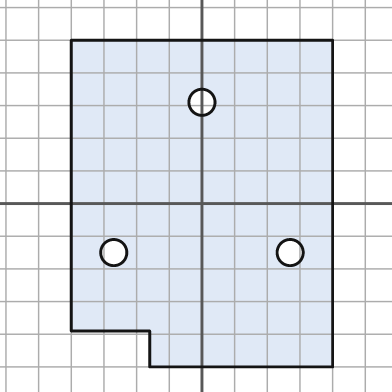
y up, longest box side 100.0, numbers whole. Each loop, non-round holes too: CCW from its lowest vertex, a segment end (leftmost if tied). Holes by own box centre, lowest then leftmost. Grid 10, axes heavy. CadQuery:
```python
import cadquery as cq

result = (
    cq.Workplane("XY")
    .moveTo(-16.0, -50.0)
    .lineTo(40.0, -50.0)
    .lineTo(40.0, 50.0)
    .lineTo(-40.0, 50.0)
    .lineTo(-40.0, -39.0)
    .lineTo(-16.0, -39.0)
    .close()
    .moveTo(-27.0, -15.0)
    .circle(4.0)
    .moveTo(27.0, -15.0)
    .circle(4.0)
    .moveTo(0.0, 31.0)
    .circle(4.0)
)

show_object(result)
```